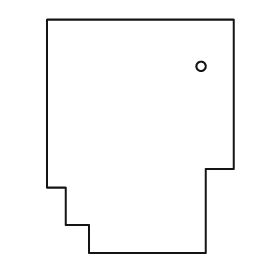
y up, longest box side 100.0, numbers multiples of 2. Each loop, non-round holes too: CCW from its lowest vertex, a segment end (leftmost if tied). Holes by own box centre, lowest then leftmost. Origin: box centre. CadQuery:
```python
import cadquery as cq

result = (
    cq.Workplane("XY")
    .moveTo(-22.0, -50.0)
    .lineTo(28.0, -50.0)
    .lineTo(28.0, -14.0)
    .lineTo(40.0, -14.0)
    .lineTo(40.0, 50.0)
    .lineTo(-40.0, 50.0)
    .lineTo(-40.0, -22.0)
    .lineTo(-32.0, -22.0)
    .lineTo(-32.0, -38.0)
    .lineTo(-22.0, -38.0)
    .close()
    .moveTo(26.0, 30.0)
    .circle(2.0)
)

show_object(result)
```